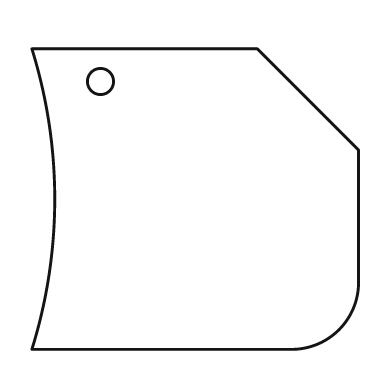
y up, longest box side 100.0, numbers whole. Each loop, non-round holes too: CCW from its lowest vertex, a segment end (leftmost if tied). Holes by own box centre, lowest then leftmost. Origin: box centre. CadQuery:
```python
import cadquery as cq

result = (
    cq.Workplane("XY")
    .moveTo(-50.0, -46.0)
    .lineTo(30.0, -46.0)
    .threePointArc((44.0, -40.0), (50.0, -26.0))
    .lineTo(50.0, 15.0)
    .lineTo(19.0, 46.0)
    .lineTo(-50.0, 46.0)
    .threePointArc((-43.0, 0.0), (-50.0, -46.0))
    .close()
    .moveTo(-29.0, 36.0)
    .circle(4.0)
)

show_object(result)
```